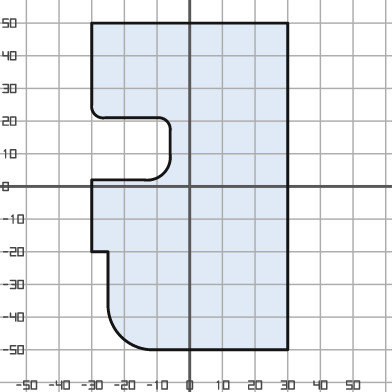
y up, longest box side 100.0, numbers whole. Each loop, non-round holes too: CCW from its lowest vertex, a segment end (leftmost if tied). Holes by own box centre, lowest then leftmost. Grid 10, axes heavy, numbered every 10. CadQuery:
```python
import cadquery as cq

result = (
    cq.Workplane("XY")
    .moveTo(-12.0, -50.0)
    .lineTo(30.0, -50.0)
    .lineTo(30.0, 50.0)
    .lineTo(-30.0, 50.0)
    .lineTo(-30.0, 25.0)
    .threePointArc((-29.0, 22.0), (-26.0, 21.0))
    .lineTo(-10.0, 21.0)
    .threePointArc((-7.0, 20.0), (-6.0, 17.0))
    .lineTo(-6.0, 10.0)
    .threePointArc((-8.0, 4.0), (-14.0, 2.0))
    .lineTo(-30.0, 2.0)
    .lineTo(-30.0, -20.0)
    .lineTo(-25.0, -20.0)
    .lineTo(-25.0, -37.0)
    .threePointArc((-21.0, -46.0), (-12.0, -50.0))
    .close()
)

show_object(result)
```